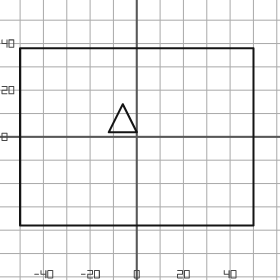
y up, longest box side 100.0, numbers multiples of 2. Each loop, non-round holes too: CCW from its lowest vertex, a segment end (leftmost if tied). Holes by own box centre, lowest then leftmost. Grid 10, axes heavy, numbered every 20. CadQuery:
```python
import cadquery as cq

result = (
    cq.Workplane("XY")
    .moveTo(-50.0, -38.0)
    .lineTo(50.0, -38.0)
    .lineTo(50.0, 38.0)
    .lineTo(-50.0, 38.0)
    .close()
    .moveTo(-12.0, 2.0)
    .lineTo(0.0, 2.0)
    .lineTo(-6.0, 14.0)
    .close()
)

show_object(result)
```